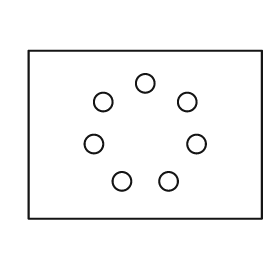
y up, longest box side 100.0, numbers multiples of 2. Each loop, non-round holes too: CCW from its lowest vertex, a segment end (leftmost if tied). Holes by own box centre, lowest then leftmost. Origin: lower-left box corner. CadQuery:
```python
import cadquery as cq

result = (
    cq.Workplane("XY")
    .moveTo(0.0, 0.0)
    .lineTo(100.0, 0.0)
    .lineTo(100.0, 72.0)
    .lineTo(0.0, 72.0)
    .close()
    .moveTo(40.0, 16.0)
    .circle(4.0)
    .moveTo(60.0, 16.0)
    .circle(4.0)
    .moveTo(28.0, 32.0)
    .circle(4.0)
    .moveTo(72.0, 32.0)
    .circle(4.0)
    .moveTo(32.0, 50.0)
    .circle(4.0)
    .moveTo(68.0, 50.0)
    .circle(4.0)
    .moveTo(50.0, 58.0)
    .circle(4.0)
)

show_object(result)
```